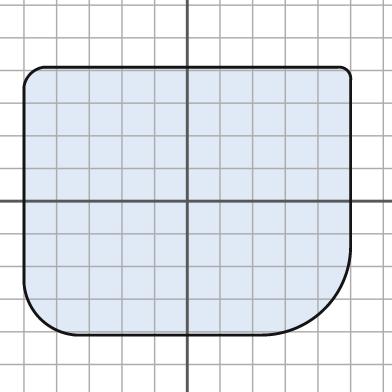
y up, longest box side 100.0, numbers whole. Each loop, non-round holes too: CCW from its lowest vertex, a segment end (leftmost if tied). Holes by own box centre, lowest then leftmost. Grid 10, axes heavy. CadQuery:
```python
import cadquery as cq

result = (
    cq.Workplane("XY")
    .moveTo(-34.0, -41.0)
    .lineTo(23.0, -41.0)
    .threePointArc((42.0, -33.0), (50.0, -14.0))
    .lineTo(50.0, 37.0)
    .threePointArc((49.0, 40.0), (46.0, 41.0))
    .lineTo(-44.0, 41.0)
    .threePointArc((-48.0, 39.0), (-50.0, 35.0))
    .lineTo(-50.0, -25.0)
    .threePointArc((-45.0, -36.0), (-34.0, -41.0))
    .close()
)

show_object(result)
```